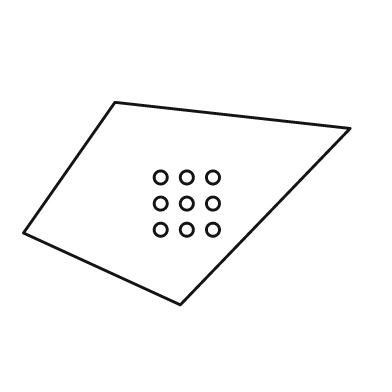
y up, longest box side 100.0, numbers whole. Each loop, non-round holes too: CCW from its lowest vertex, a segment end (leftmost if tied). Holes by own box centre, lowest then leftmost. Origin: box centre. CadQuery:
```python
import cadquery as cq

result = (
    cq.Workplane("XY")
    .moveTo(-2.0, -31.0)
    .lineTo(50.0, 23.0)
    .lineTo(-22.0, 31.0)
    .lineTo(-50.0, -9.0)
    .close()
    .moveTo(-8.0, -8.0)
    .circle(2.0)
    .moveTo(0.0, -8.0)
    .circle(2.0)
    .moveTo(8.0, -8.0)
    .circle(2.0)
    .moveTo(-8.0, 0.0)
    .circle(2.0)
    .moveTo(0.0, 0.0)
    .circle(2.0)
    .moveTo(8.0, 0.0)
    .circle(2.0)
    .moveTo(-8.0, 8.0)
    .circle(2.0)
    .moveTo(0.0, 8.0)
    .circle(2.0)
    .moveTo(8.0, 8.0)
    .circle(2.0)
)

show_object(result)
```